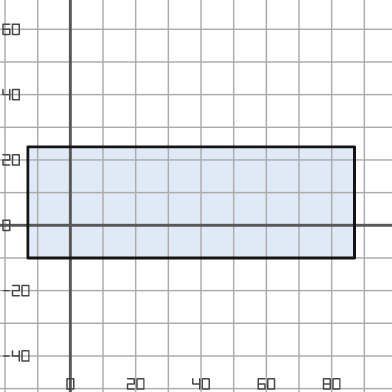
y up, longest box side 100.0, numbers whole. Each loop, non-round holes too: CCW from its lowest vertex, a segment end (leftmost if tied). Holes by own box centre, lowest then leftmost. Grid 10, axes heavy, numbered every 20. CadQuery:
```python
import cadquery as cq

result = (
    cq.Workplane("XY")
    .moveTo(-13.0, -10.0)
    .lineTo(87.0, -10.0)
    .lineTo(87.0, 24.0)
    .lineTo(-13.0, 24.0)
    .close()
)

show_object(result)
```